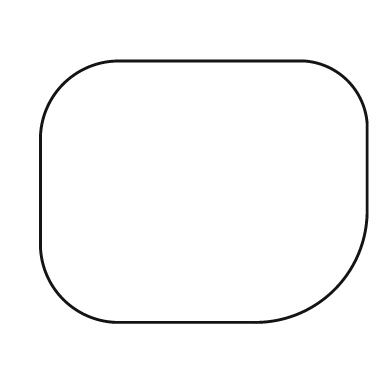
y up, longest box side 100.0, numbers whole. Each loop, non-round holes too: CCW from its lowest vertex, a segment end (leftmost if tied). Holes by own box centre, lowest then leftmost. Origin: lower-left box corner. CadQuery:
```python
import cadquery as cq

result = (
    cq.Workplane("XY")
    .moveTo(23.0, 0.0)
    .lineTo(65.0, 0.0)
    .threePointArc((90.0, 10.0), (100.0, 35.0))
    .lineTo(100.0, 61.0)
    .threePointArc((94.0, 74.0), (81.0, 80.0))
    .lineTo(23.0, 80.0)
    .threePointArc((7.0, 73.0), (0.0, 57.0))
    .lineTo(0.0, 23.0)
    .threePointArc((7.0, 7.0), (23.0, 0.0))
    .close()
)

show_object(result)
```